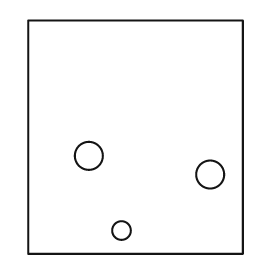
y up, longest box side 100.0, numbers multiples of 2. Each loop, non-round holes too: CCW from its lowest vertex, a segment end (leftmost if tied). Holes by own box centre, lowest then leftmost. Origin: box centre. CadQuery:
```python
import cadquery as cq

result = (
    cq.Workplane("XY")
    .moveTo(-46.0, -50.0)
    .lineTo(46.0, -50.0)
    .lineTo(46.0, 50.0)
    .lineTo(-46.0, 50.0)
    .close()
    .moveTo(-6.0, -40.0)
    .circle(4.0)
    .moveTo(32.0, -16.0)
    .circle(6.0)
    .moveTo(-20.0, -8.0)
    .circle(6.0)
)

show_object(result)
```